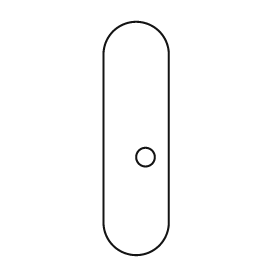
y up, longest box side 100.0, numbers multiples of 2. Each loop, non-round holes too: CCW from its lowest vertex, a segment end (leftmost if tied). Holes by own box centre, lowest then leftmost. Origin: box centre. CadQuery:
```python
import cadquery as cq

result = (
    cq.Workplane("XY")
    .moveTo(-14.0, -36.0)
    .threePointArc((0.0, -50.0), (14.0, -36.0))
    .lineTo(14.0, 36.0)
    .threePointArc((0.0, 50.0), (-14.0, 36.0))
    .close()
    .moveTo(4.0, -8.0)
    .circle(4.0)
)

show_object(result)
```